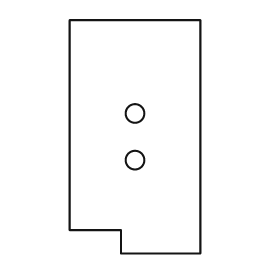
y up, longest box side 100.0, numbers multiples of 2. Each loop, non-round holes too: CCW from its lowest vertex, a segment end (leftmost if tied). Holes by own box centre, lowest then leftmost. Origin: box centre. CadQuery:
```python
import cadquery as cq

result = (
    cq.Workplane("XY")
    .moveTo(-6.0, -50.0)
    .lineTo(28.0, -50.0)
    .lineTo(28.0, 50.0)
    .lineTo(-28.0, 50.0)
    .lineTo(-28.0, -40.0)
    .lineTo(-6.0, -40.0)
    .close()
    .moveTo(0.0, -10.0)
    .circle(4.0)
    .moveTo(0.0, 10.0)
    .circle(4.0)
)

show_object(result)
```